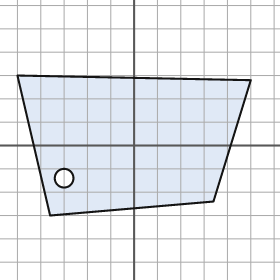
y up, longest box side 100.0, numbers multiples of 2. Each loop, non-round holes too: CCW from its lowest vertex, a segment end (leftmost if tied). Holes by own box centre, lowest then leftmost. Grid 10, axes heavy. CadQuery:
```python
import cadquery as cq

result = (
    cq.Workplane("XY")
    .moveTo(-36.0, -30.0)
    .lineTo(34.0, -24.0)
    .lineTo(50.0, 28.0)
    .lineTo(-50.0, 30.0)
    .close()
    .moveTo(-30.0, -14.0)
    .circle(4.0)
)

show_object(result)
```